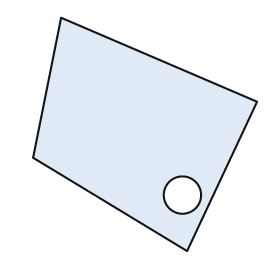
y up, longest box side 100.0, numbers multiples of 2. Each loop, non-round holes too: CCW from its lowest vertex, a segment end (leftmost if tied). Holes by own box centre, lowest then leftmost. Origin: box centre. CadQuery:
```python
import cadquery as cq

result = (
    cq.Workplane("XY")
    .moveTo(18.0, -50.0)
    .lineTo(48.0, 14.0)
    .lineTo(-36.0, 50.0)
    .lineTo(-48.0, -10.0)
    .close()
    .moveTo(16.0, -26.0)
    .circle(8.0)
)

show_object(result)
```